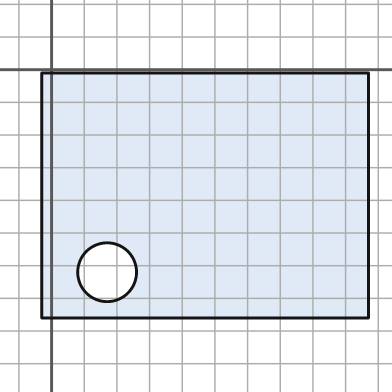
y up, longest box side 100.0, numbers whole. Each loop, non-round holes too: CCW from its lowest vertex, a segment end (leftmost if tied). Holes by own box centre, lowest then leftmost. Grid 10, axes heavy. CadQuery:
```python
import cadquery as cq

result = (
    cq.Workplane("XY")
    .moveTo(-3.0, -76.0)
    .lineTo(97.0, -76.0)
    .lineTo(97.0, -1.0)
    .lineTo(-3.0, -1.0)
    .close()
    .moveTo(17.0, -62.0)
    .circle(9.0)
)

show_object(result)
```